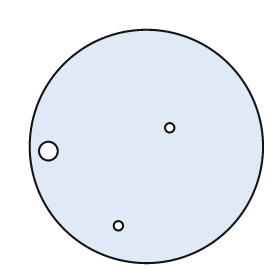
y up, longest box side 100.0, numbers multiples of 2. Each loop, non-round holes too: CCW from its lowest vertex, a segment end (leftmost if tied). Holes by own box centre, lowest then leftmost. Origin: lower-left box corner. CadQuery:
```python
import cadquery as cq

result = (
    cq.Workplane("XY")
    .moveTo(50.0, 50.0)
    .circle(50.0)
    .moveTo(38.0, 16.0)
    .circle(2.0)
    .moveTo(8.0, 48.0)
    .circle(4.0)
    .moveTo(60.0, 58.0)
    .circle(2.0)
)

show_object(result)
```